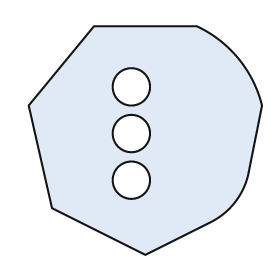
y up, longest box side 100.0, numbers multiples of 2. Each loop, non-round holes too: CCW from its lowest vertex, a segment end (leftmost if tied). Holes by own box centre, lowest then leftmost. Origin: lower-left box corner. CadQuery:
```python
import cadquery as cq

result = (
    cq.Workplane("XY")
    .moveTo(50.0, 0.0)
    .lineTo(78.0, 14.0)
    .threePointArc((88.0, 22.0), (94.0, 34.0))
    .lineTo(100.0, 64.0)
    .threePointArc((90.0, 84.0), (72.0, 98.0))
    .lineTo(28.0, 98.0)
    .lineTo(0.0, 64.0)
    .lineTo(10.0, 20.0)
    .close()
    .moveTo(44.0, 32.0)
    .circle(8.0)
    .moveTo(44.0, 52.0)
    .circle(8.0)
    .moveTo(44.0, 72.0)
    .circle(8.0)
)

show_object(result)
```